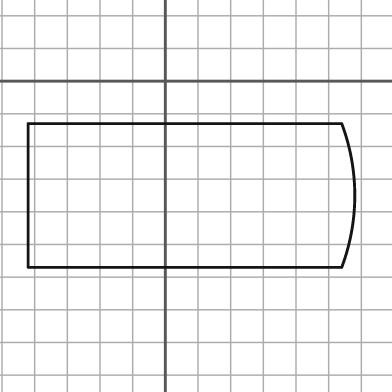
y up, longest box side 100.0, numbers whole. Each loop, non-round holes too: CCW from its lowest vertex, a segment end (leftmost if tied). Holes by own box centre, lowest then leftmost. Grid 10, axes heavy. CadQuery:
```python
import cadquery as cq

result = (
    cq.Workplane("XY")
    .moveTo(-42.0, -57.0)
    .lineTo(54.0, -57.0)
    .threePointArc((58.0, -35.0), (54.0, -13.0))
    .lineTo(-42.0, -13.0)
    .close()
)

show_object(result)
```